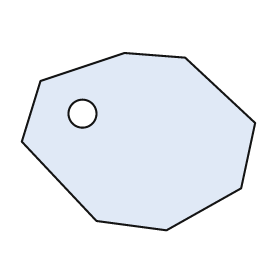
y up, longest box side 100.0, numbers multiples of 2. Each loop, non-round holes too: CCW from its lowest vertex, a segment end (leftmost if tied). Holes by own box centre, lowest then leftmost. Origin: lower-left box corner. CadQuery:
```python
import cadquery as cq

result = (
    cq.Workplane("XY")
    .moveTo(62.0, 0.0)
    .lineTo(94.0, 18.0)
    .lineTo(100.0, 46.0)
    .lineTo(70.0, 74.0)
    .lineTo(44.0, 76.0)
    .lineTo(8.0, 64.0)
    .lineTo(0.0, 38.0)
    .lineTo(32.0, 4.0)
    .close()
    .moveTo(26.0, 50.0)
    .circle(6.0)
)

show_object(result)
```